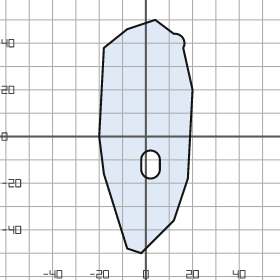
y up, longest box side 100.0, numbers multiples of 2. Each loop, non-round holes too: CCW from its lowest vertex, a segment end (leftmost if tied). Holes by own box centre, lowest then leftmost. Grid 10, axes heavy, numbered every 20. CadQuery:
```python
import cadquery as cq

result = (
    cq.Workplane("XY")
    .moveTo(-2.0, -50.0)
    .lineTo(12.0, -36.0)
    .lineTo(18.0, -18.0)
    .lineTo(20.0, 20.0)
    .lineTo(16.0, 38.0)
    .threePointArc((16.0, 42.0), (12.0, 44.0))
    .lineTo(4.0, 50.0)
    .lineTo(-8.0, 46.0)
    .lineTo(-18.0, 38.0)
    .lineTo(-20.0, 0.0)
    .lineTo(-18.0, -16.0)
    .lineTo(-8.0, -48.0)
    .close()
    .moveTo(-2.0, -14.0)
    .threePointArc((2.0, -18.0), (6.0, -14.0))
    .lineTo(6.0, -10.0)
    .threePointArc((2.0, -6.0), (-2.0, -10.0))
    .close()
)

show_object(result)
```